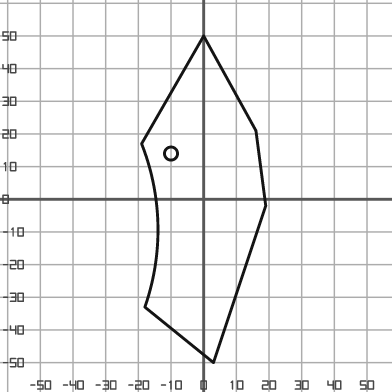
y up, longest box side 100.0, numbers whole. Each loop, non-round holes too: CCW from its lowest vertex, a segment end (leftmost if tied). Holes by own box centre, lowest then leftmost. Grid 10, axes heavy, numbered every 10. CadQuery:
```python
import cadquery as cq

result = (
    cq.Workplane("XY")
    .moveTo(3.0, -50.0)
    .lineTo(19.0, -2.0)
    .lineTo(16.0, 21.0)
    .lineTo(0.0, 50.0)
    .lineTo(-19.0, 17.0)
    .threePointArc((-14.0, -8.0), (-18.0, -33.0))
    .close()
    .moveTo(-10.0, 14.0)
    .circle(2.0)
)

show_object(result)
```